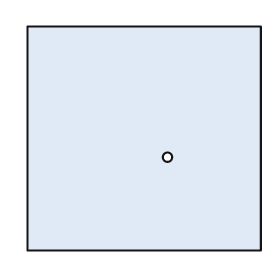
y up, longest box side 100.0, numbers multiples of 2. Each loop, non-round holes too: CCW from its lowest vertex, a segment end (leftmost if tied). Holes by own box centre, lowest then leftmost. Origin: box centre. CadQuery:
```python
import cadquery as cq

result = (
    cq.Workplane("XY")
    .moveTo(-50.0, -48.0)
    .lineTo(50.0, -48.0)
    .lineTo(50.0, 48.0)
    .lineTo(-50.0, 48.0)
    .close()
    .moveTo(10.0, -8.0)
    .circle(2.0)
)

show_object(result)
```